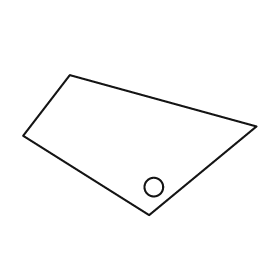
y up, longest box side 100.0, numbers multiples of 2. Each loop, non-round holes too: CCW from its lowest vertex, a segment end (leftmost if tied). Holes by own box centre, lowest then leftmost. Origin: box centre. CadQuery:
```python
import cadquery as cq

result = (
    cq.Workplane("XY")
    .moveTo(4.0, -30.0)
    .lineTo(50.0, 8.0)
    .lineTo(-30.0, 30.0)
    .lineTo(-50.0, 4.0)
    .close()
    .moveTo(6.0, -18.0)
    .circle(4.0)
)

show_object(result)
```